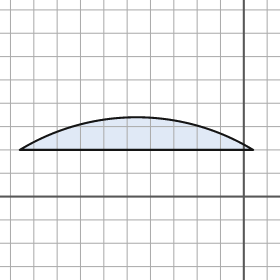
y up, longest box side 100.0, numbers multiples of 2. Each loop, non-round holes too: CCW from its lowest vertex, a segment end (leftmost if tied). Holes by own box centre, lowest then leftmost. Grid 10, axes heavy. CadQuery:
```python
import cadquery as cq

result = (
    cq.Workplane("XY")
    .moveTo(-96.0, 20.0)
    .lineTo(4.0, 20.0)
    .threePointArc((-46.0, 34.0), (-96.0, 20.0))
    .close()
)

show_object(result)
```